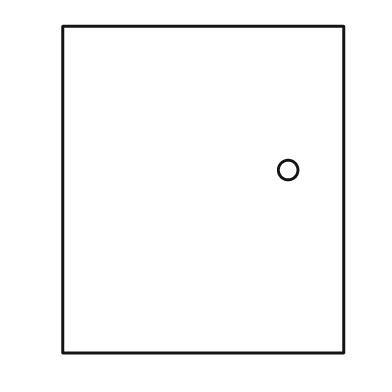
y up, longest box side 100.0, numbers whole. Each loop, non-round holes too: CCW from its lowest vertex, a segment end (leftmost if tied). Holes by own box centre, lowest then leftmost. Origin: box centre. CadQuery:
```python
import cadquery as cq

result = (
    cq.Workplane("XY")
    .moveTo(-43.0, -50.0)
    .lineTo(43.0, -50.0)
    .lineTo(43.0, 50.0)
    .lineTo(-43.0, 50.0)
    .close()
    .moveTo(26.0, 6.0)
    .circle(3.0)
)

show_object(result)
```